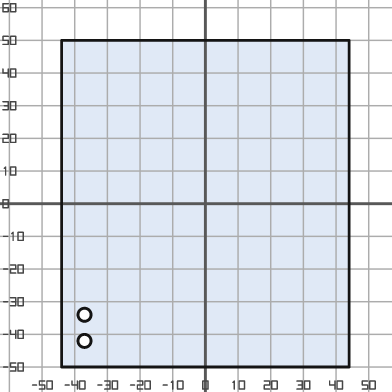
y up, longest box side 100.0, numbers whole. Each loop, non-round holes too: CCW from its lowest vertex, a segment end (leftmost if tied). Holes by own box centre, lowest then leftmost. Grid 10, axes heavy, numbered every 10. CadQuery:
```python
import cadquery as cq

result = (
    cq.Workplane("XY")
    .moveTo(-44.0, -50.0)
    .lineTo(44.0, -50.0)
    .lineTo(44.0, 50.0)
    .lineTo(-44.0, 50.0)
    .close()
    .moveTo(-37.0, -42.0)
    .circle(2.0)
    .moveTo(-37.0, -34.0)
    .circle(2.0)
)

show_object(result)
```